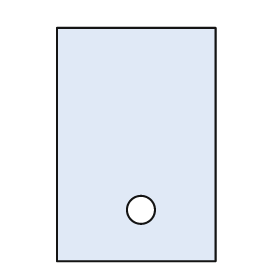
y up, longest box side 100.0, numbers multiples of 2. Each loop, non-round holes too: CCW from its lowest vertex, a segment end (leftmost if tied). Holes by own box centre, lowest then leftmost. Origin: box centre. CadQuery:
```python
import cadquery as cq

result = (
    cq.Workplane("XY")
    .moveTo(-34.0, -50.0)
    .lineTo(34.0, -50.0)
    .lineTo(34.0, 50.0)
    .lineTo(-34.0, 50.0)
    .close()
    .moveTo(2.0, -28.0)
    .circle(6.0)
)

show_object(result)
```